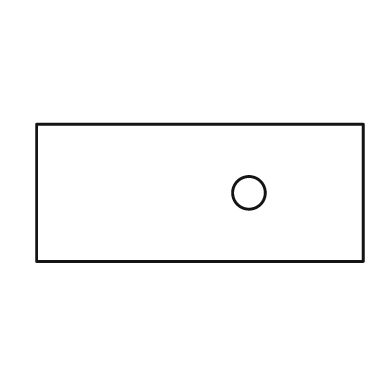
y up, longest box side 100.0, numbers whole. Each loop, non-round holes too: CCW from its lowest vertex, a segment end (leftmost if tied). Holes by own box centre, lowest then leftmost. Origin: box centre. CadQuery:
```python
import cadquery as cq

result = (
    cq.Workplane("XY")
    .moveTo(-50.0, -21.0)
    .lineTo(50.0, -21.0)
    .lineTo(50.0, 21.0)
    .lineTo(-50.0, 21.0)
    .close()
    .moveTo(15.0, 0.0)
    .circle(5.0)
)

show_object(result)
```